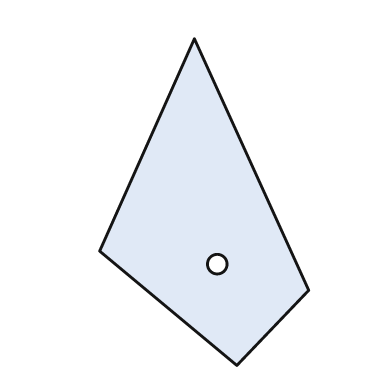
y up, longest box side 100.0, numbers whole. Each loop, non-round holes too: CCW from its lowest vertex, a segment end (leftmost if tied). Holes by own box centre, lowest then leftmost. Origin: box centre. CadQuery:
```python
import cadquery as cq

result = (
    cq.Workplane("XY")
    .moveTo(10.0, -50.0)
    .lineTo(32.0, -27.0)
    .lineTo(-3.0, 50.0)
    .lineTo(-32.0, -15.0)
    .close()
    .moveTo(4.0, -19.0)
    .circle(3.0)
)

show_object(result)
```